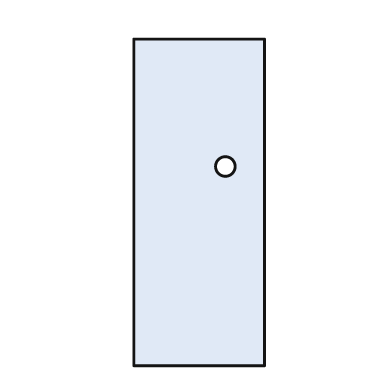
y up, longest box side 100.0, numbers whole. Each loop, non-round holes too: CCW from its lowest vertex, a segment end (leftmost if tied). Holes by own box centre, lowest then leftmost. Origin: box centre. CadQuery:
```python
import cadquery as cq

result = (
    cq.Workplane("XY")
    .moveTo(-20.0, -50.0)
    .lineTo(20.0, -50.0)
    .lineTo(20.0, 50.0)
    .lineTo(-20.0, 50.0)
    .close()
    .moveTo(8.0, 11.0)
    .circle(3.0)
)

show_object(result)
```